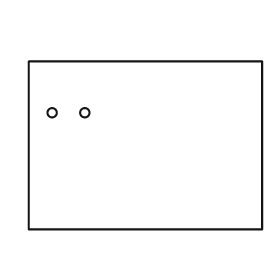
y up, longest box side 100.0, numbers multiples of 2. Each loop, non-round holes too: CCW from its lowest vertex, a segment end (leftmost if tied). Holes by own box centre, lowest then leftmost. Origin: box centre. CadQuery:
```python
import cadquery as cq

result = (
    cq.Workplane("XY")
    .moveTo(-50.0, -36.0)
    .lineTo(50.0, -36.0)
    .lineTo(50.0, 36.0)
    .lineTo(-50.0, 36.0)
    .close()
    .moveTo(-40.0, 14.0)
    .circle(2.0)
    .moveTo(-26.0, 14.0)
    .circle(2.0)
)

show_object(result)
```